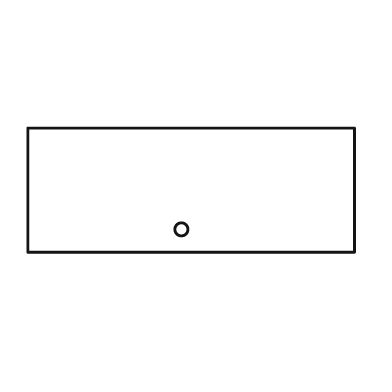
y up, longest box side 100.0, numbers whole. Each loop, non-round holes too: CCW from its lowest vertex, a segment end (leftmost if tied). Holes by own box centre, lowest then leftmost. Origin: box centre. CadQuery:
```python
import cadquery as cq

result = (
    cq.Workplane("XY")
    .moveTo(-50.0, -19.0)
    .lineTo(50.0, -19.0)
    .lineTo(50.0, 19.0)
    .lineTo(-50.0, 19.0)
    .close()
    .moveTo(-3.0, -12.0)
    .circle(2.0)
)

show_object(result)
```